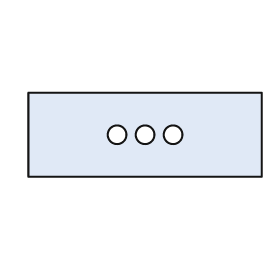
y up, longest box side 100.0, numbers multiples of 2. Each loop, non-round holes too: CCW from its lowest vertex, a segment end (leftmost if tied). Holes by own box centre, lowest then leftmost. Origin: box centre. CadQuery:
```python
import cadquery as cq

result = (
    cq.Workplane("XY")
    .moveTo(-50.0, -18.0)
    .lineTo(50.0, -18.0)
    .lineTo(50.0, 18.0)
    .lineTo(-50.0, 18.0)
    .close()
    .moveTo(-12.0, 0.0)
    .circle(4.0)
    .moveTo(0.0, 0.0)
    .circle(4.0)
    .moveTo(12.0, 0.0)
    .circle(4.0)
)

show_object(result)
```